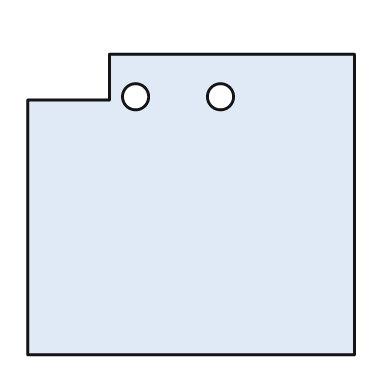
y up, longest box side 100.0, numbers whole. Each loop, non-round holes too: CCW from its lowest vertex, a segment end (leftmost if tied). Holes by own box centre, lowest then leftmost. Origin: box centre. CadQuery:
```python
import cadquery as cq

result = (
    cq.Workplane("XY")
    .moveTo(-50.0, -46.0)
    .lineTo(50.0, -46.0)
    .lineTo(50.0, 46.0)
    .lineTo(-25.0, 46.0)
    .lineTo(-25.0, 32.0)
    .lineTo(-50.0, 32.0)
    .close()
    .moveTo(-17.0, 33.0)
    .circle(4.0)
    .moveTo(9.0, 33.0)
    .circle(4.0)
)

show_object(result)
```